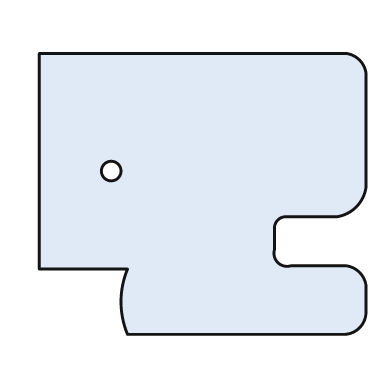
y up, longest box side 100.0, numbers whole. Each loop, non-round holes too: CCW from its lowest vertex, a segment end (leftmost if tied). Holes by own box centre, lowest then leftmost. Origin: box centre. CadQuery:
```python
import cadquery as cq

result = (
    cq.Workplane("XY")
    .moveTo(-23.0, -43.0)
    .lineTo(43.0, -43.0)
    .threePointArc((48.0, -41.0), (50.0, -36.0))
    .lineTo(50.0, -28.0)
    .threePointArc((48.0, -24.0), (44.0, -22.0))
    .lineTo(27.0, -22.0)
    .threePointArc((23.0, -21.0), (22.0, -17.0))
    .lineTo(22.0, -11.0)
    .threePointArc((23.0, -8.0), (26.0, -7.0))
    .lineTo(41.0, -7.0)
    .threePointArc((47.0, -4.0), (50.0, 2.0))
    .lineTo(50.0, 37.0)
    .threePointArc((48.0, 41.0), (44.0, 43.0))
    .lineTo(-50.0, 43.0)
    .lineTo(-50.0, -23.0)
    .lineTo(-23.0, -23.0)
    .threePointArc((-25.0, -33.0), (-23.0, -43.0))
    .close()
    .moveTo(-28.0, 7.0)
    .circle(3.0)
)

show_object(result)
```